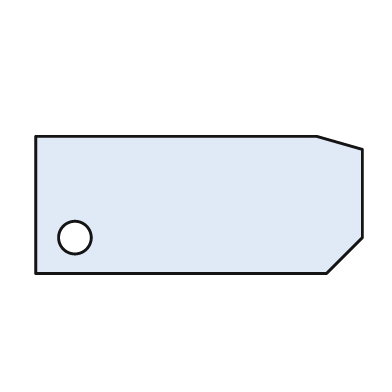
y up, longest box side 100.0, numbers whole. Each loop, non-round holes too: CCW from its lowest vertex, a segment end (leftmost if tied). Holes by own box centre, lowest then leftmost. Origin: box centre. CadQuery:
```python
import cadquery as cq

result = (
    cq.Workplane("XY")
    .moveTo(-50.0, -21.0)
    .lineTo(39.0, -21.0)
    .lineTo(50.0, -10.0)
    .lineTo(50.0, 17.0)
    .lineTo(36.0, 21.0)
    .lineTo(-50.0, 21.0)
    .close()
    .moveTo(-38.0, -10.0)
    .circle(5.0)
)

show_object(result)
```